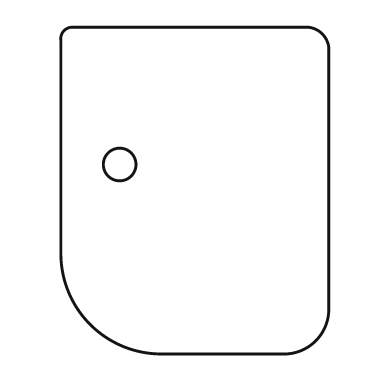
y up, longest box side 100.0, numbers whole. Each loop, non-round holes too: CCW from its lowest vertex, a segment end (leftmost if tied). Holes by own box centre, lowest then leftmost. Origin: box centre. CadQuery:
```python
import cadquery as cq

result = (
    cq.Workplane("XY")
    .moveTo(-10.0, -50.0)
    .lineTo(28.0, -50.0)
    .threePointArc((37.0, -46.0), (41.0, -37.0))
    .lineTo(41.0, 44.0)
    .threePointArc((39.0, 48.0), (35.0, 50.0))
    .lineTo(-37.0, 50.0)
    .threePointArc((-40.0, 49.0), (-41.0, 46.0))
    .lineTo(-41.0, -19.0)
    .threePointArc((-32.0, -41.0), (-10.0, -50.0))
    .close()
    .moveTo(-23.0, 8.0)
    .circle(5.0)
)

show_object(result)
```